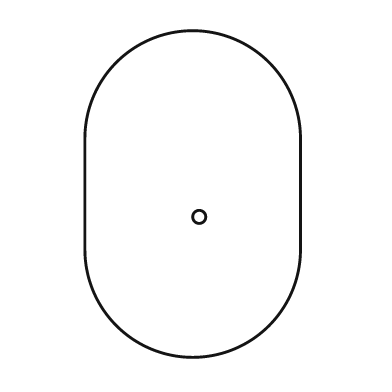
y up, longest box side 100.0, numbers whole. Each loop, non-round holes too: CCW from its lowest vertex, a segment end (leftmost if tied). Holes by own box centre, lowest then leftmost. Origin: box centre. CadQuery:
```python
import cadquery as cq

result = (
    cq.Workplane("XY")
    .moveTo(-33.0, -17.0)
    .threePointArc((0.0, -50.0), (33.0, -17.0))
    .lineTo(33.0, 17.0)
    .threePointArc((0.0, 50.0), (-33.0, 17.0))
    .close()
    .moveTo(2.0, -7.0)
    .circle(2.0)
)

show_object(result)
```